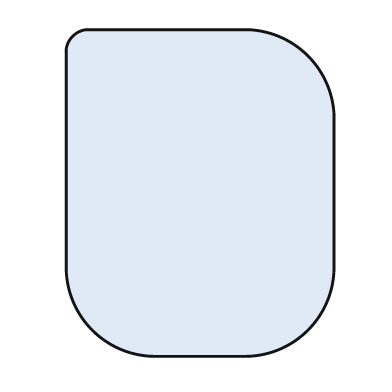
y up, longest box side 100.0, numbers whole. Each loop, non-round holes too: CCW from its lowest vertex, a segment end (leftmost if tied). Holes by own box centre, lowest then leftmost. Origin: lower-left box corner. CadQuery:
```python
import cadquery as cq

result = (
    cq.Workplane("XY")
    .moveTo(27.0, 0.0)
    .lineTo(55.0, 0.0)
    .threePointArc((74.0, 8.0), (82.0, 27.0))
    .lineTo(82.0, 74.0)
    .threePointArc((74.0, 92.0), (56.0, 100.0))
    .lineTo(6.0, 100.0)
    .threePointArc((2.0, 98.0), (0.0, 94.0))
    .lineTo(0.0, 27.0)
    .threePointArc((8.0, 8.0), (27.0, 0.0))
    .close()
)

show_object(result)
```